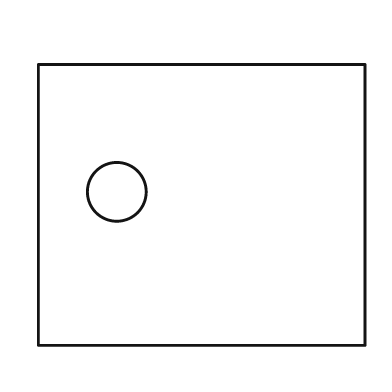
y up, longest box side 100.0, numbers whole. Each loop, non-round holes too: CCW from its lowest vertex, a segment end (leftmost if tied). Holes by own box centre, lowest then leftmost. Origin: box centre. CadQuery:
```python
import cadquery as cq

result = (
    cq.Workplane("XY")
    .moveTo(-50.0, -43.0)
    .lineTo(50.0, -43.0)
    .lineTo(50.0, 43.0)
    .lineTo(-50.0, 43.0)
    .close()
    .moveTo(-26.0, 4.0)
    .circle(9.0)
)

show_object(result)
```